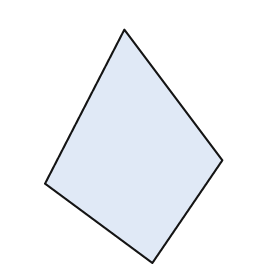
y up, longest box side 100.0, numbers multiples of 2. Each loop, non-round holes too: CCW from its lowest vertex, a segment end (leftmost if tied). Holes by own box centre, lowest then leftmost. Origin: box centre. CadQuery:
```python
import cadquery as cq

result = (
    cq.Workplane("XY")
    .moveTo(8.0, -50.0)
    .lineTo(38.0, -6.0)
    .lineTo(-4.0, 50.0)
    .lineTo(-38.0, -16.0)
    .close()
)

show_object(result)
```